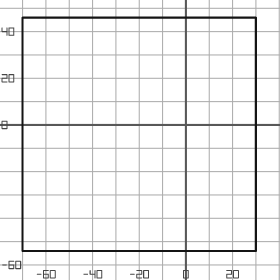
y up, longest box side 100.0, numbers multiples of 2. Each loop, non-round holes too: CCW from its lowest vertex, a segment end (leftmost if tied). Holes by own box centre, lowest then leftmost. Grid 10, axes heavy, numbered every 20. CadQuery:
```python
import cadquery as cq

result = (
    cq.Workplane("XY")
    .moveTo(-70.0, -54.0)
    .lineTo(30.0, -54.0)
    .lineTo(30.0, 46.0)
    .lineTo(-70.0, 46.0)
    .close()
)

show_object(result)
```